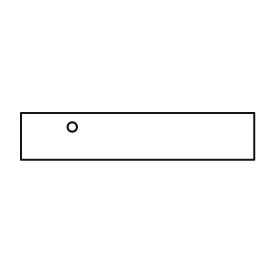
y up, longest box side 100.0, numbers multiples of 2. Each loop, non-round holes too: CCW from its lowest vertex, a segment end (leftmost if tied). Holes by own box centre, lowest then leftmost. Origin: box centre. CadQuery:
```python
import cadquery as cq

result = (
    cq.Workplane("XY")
    .moveTo(-50.0, -10.0)
    .lineTo(50.0, -10.0)
    .lineTo(50.0, 10.0)
    .lineTo(-50.0, 10.0)
    .close()
    .moveTo(-28.0, 4.0)
    .circle(2.0)
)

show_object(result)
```